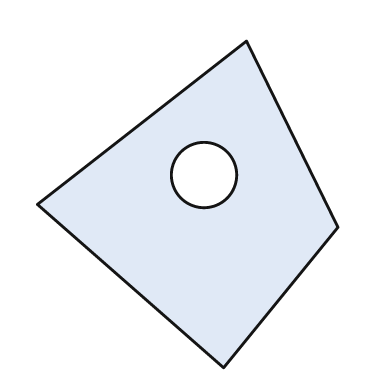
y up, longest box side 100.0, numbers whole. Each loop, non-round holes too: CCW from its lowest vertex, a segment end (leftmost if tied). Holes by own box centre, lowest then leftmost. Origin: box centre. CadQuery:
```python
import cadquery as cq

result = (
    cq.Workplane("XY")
    .moveTo(11.0, -50.0)
    .lineTo(46.0, -7.0)
    .lineTo(18.0, 50.0)
    .lineTo(-46.0, 0.0)
    .close()
    .moveTo(5.0, 9.0)
    .circle(10.0)
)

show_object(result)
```